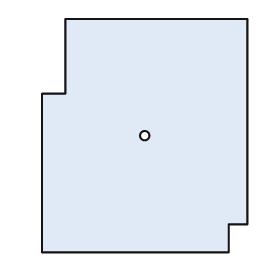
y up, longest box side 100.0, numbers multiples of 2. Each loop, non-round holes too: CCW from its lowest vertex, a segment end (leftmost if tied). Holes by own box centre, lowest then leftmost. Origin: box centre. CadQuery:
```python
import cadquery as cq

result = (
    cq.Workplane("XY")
    .moveTo(-44.0, -50.0)
    .lineTo(36.0, -50.0)
    .lineTo(36.0, -38.0)
    .lineTo(44.0, -38.0)
    .lineTo(44.0, 50.0)
    .lineTo(-34.0, 50.0)
    .lineTo(-34.0, 18.0)
    .lineTo(-44.0, 18.0)
    .close()
    .moveTo(0.0, 0.0)
    .circle(2.0)
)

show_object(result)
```